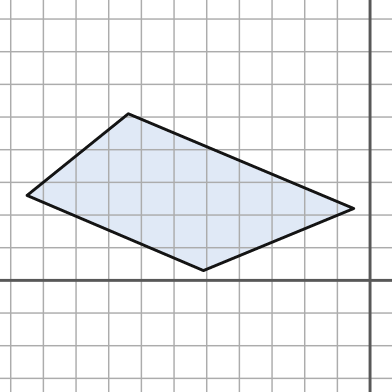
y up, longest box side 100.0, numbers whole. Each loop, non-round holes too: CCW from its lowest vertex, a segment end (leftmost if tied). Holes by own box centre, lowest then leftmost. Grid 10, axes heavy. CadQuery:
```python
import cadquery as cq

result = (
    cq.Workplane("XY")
    .moveTo(-51.0, 3.0)
    .lineTo(-5.0, 22.0)
    .lineTo(-74.0, 51.0)
    .lineTo(-105.0, 26.0)
    .close()
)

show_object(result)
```